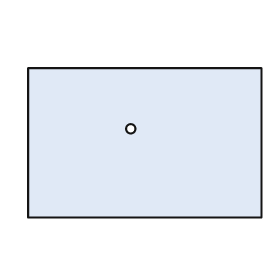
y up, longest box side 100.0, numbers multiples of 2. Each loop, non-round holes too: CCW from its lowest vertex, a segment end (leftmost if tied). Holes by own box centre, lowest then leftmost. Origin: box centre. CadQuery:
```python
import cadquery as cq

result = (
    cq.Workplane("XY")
    .moveTo(-50.0, -32.0)
    .lineTo(50.0, -32.0)
    .lineTo(50.0, 32.0)
    .lineTo(-50.0, 32.0)
    .close()
    .moveTo(-6.0, 6.0)
    .circle(2.0)
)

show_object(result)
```